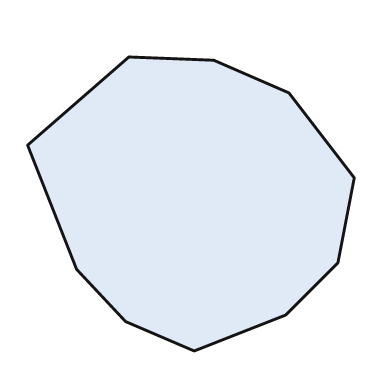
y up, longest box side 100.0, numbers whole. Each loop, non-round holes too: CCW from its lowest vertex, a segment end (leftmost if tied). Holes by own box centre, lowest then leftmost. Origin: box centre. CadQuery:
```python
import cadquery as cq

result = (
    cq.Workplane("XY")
    .moveTo(1.0, -45.0)
    .lineTo(29.0, -34.0)
    .lineTo(45.0, -18.0)
    .lineTo(50.0, 8.0)
    .lineTo(30.0, 34.0)
    .lineTo(7.0, 44.0)
    .lineTo(-19.0, 45.0)
    .lineTo(-50.0, 18.0)
    .lineTo(-35.0, -20.0)
    .lineTo(-20.0, -36.0)
    .close()
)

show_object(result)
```